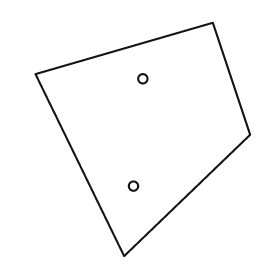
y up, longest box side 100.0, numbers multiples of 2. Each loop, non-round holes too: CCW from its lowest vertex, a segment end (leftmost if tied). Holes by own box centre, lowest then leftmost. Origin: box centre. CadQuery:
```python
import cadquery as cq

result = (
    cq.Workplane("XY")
    .moveTo(-8.0, -50.0)
    .lineTo(46.0, 2.0)
    .lineTo(30.0, 50.0)
    .lineTo(-46.0, 28.0)
    .close()
    .moveTo(-4.0, -20.0)
    .circle(2.0)
    .moveTo(0.0, 26.0)
    .circle(2.0)
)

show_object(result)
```